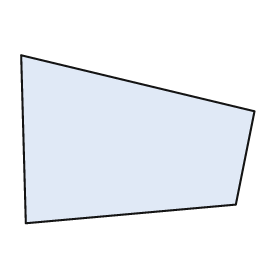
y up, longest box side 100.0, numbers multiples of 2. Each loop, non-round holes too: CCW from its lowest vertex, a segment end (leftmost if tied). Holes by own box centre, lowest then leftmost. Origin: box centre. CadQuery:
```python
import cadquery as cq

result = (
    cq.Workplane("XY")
    .moveTo(-48.0, -36.0)
    .lineTo(42.0, -28.0)
    .lineTo(50.0, 12.0)
    .lineTo(-50.0, 36.0)
    .close()
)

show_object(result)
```